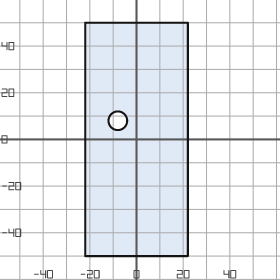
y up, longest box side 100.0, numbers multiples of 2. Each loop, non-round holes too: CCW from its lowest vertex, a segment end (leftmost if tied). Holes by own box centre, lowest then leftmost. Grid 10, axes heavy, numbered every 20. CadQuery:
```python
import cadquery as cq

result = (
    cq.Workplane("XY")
    .moveTo(-22.0, -50.0)
    .lineTo(22.0, -50.0)
    .lineTo(22.0, 50.0)
    .lineTo(-22.0, 50.0)
    .close()
    .moveTo(-8.0, 8.0)
    .circle(4.0)
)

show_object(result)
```